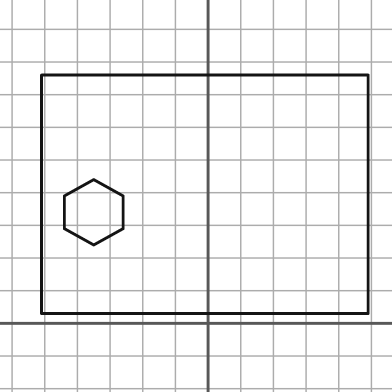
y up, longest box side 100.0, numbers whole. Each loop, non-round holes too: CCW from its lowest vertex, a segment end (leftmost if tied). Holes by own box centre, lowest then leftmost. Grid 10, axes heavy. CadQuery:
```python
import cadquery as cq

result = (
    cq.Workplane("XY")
    .moveTo(-51.0, 3.0)
    .lineTo(49.0, 3.0)
    .lineTo(49.0, 76.0)
    .lineTo(-51.0, 76.0)
    .close()
    .moveTo(-35.0, 24.0)
    .lineTo(-26.0, 29.0)
    .lineTo(-26.0, 39.0)
    .lineTo(-35.0, 44.0)
    .lineTo(-44.0, 39.0)
    .lineTo(-44.0, 29.0)
    .close()
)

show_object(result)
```